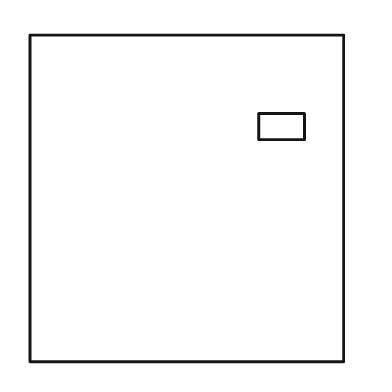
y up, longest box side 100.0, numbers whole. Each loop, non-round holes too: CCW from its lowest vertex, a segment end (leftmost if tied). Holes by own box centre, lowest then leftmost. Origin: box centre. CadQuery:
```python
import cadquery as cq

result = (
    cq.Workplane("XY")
    .moveTo(-48.0, -50.0)
    .lineTo(48.0, -50.0)
    .lineTo(48.0, 50.0)
    .lineTo(-48.0, 50.0)
    .close()
    .moveTo(22.0, 18.0)
    .lineTo(36.0, 18.0)
    .lineTo(36.0, 26.0)
    .lineTo(22.0, 26.0)
    .close()
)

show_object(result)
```